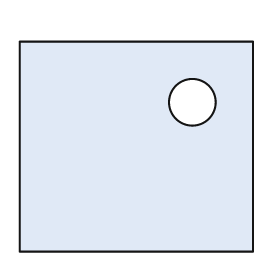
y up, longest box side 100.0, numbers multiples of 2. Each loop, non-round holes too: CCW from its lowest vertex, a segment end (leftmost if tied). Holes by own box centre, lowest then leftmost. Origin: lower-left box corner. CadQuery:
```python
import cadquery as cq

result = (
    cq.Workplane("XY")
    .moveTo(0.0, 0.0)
    .lineTo(100.0, 0.0)
    .lineTo(100.0, 90.0)
    .lineTo(0.0, 90.0)
    .close()
    .moveTo(74.0, 64.0)
    .circle(10.0)
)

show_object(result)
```